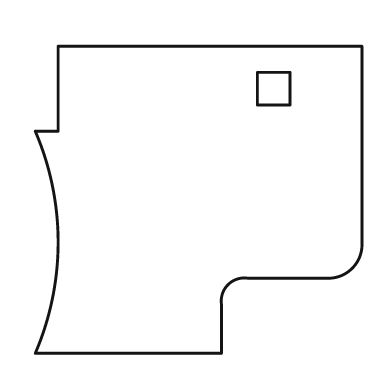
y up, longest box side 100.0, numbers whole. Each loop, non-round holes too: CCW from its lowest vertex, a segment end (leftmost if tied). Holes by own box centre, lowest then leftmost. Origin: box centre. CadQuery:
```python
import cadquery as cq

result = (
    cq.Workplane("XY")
    .moveTo(-50.0, -47.0)
    .lineTo(7.0, -47.0)
    .lineTo(7.0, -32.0)
    .threePointArc((9.0, -26.0), (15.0, -24.0))
    .lineTo(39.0, -24.0)
    .threePointArc((47.0, -21.0), (50.0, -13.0))
    .lineTo(50.0, 47.0)
    .lineTo(-43.0, 47.0)
    .lineTo(-43.0, 21.0)
    .lineTo(-50.0, 21.0)
    .threePointArc((-43.0, -13.0), (-50.0, -47.0))
    .close()
    .moveTo(18.0, 29.0)
    .lineTo(28.0, 29.0)
    .lineTo(28.0, 39.0)
    .lineTo(18.0, 39.0)
    .close()
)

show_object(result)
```